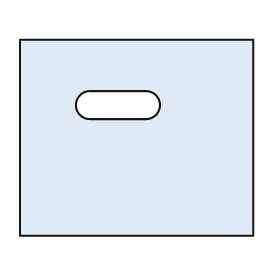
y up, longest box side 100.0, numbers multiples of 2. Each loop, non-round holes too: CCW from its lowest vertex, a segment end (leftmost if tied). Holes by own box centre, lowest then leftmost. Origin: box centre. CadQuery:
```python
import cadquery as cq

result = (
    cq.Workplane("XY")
    .moveTo(-50.0, -42.0)
    .lineTo(50.0, -42.0)
    .lineTo(50.0, 42.0)
    .lineTo(-50.0, 42.0)
    .close()
    .moveTo(-20.0, 8.0)
    .lineTo(4.0, 8.0)
    .threePointArc((10.0, 14.0), (4.0, 20.0))
    .lineTo(-20.0, 20.0)
    .threePointArc((-26.0, 14.0), (-20.0, 8.0))
    .close()
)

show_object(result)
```